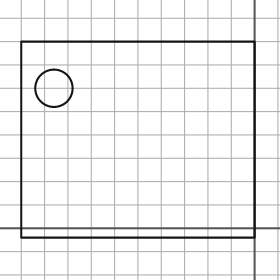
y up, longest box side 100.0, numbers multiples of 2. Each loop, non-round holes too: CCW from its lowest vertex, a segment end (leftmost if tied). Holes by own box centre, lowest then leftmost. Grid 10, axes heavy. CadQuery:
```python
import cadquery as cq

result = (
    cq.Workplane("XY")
    .moveTo(-100.0, -4.0)
    .lineTo(0.0, -4.0)
    .lineTo(0.0, 80.0)
    .lineTo(-100.0, 80.0)
    .close()
    .moveTo(-86.0, 60.0)
    .circle(8.0)
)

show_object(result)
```